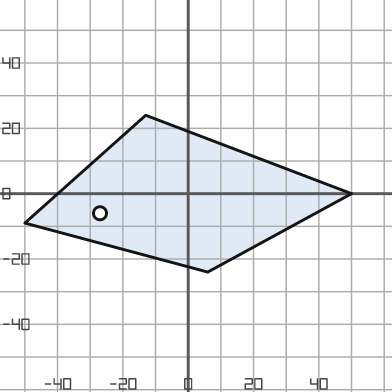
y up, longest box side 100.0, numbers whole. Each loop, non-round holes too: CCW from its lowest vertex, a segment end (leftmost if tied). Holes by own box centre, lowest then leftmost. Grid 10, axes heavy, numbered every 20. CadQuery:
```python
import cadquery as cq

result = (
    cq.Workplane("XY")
    .moveTo(6.0, -24.0)
    .lineTo(50.0, 0.0)
    .lineTo(-13.0, 24.0)
    .lineTo(-50.0, -9.0)
    .close()
    .moveTo(-27.0, -6.0)
    .circle(2.0)
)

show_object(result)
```